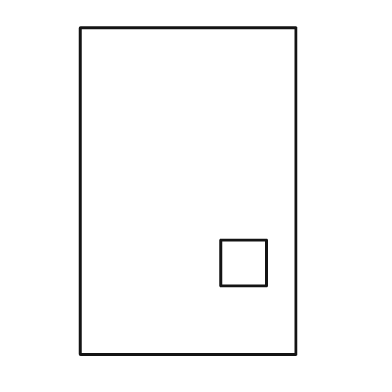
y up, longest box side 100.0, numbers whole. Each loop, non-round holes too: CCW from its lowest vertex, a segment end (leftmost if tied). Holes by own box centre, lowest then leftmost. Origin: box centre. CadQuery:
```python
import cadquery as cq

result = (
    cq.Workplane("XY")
    .moveTo(-33.0, -50.0)
    .lineTo(33.0, -50.0)
    .lineTo(33.0, 50.0)
    .lineTo(-33.0, 50.0)
    .close()
    .moveTo(10.0, -29.0)
    .lineTo(24.0, -29.0)
    .lineTo(24.0, -15.0)
    .lineTo(10.0, -15.0)
    .close()
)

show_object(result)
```